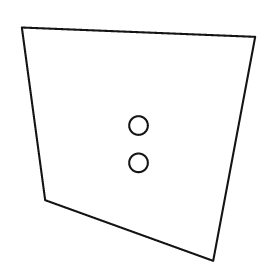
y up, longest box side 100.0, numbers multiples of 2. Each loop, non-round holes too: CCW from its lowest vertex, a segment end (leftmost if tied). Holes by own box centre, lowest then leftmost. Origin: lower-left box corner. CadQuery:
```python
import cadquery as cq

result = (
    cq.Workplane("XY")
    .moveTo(82.0, 0.0)
    .lineTo(100.0, 96.0)
    .lineTo(0.0, 100.0)
    .lineTo(10.0, 26.0)
    .close()
    .moveTo(50.0, 42.0)
    .circle(4.0)
    .moveTo(50.0, 58.0)
    .circle(4.0)
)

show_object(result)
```